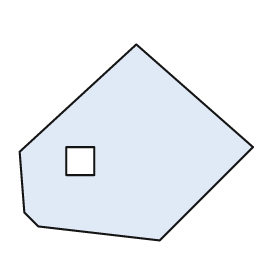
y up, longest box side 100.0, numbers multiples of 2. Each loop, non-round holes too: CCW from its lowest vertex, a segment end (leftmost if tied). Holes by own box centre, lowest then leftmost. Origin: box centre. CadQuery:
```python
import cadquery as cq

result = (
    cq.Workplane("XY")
    .moveTo(10.0, -42.0)
    .lineTo(50.0, -2.0)
    .lineTo(0.0, 42.0)
    .lineTo(-50.0, -4.0)
    .lineTo(-48.0, -30.0)
    .lineTo(-42.0, -36.0)
    .close()
    .moveTo(-30.0, -14.0)
    .lineTo(-18.0, -14.0)
    .lineTo(-18.0, -2.0)
    .lineTo(-30.0, -2.0)
    .close()
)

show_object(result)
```